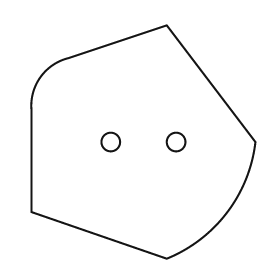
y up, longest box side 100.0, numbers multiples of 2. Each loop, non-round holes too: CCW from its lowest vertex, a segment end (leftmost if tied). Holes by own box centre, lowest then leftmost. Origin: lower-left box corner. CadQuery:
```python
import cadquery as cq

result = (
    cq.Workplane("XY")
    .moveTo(58.0, 0.0)
    .threePointArc((84.0, 20.0), (96.0, 50.0))
    .lineTo(58.0, 100.0)
    .lineTo(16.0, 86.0)
    .threePointArc((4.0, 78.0), (0.0, 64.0))
    .lineTo(0.0, 20.0)
    .close()
    .moveTo(34.0, 50.0)
    .circle(4.0)
    .moveTo(62.0, 50.0)
    .circle(4.0)
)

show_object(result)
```